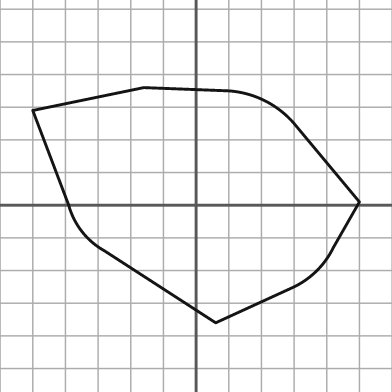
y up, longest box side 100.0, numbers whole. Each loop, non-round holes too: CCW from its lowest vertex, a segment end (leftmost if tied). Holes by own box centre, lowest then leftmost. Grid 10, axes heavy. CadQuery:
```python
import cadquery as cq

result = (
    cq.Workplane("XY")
    .moveTo(6.0, -36.0)
    .lineTo(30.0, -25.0)
    .threePointArc((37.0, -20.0), (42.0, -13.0))
    .lineTo(50.0, 1.0)
    .lineTo(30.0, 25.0)
    .threePointArc((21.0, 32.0), (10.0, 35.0))
    .lineTo(-16.0, 36.0)
    .lineTo(-50.0, 29.0)
    .lineTo(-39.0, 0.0)
    .threePointArc((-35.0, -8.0), (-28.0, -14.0))
    .close()
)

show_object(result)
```